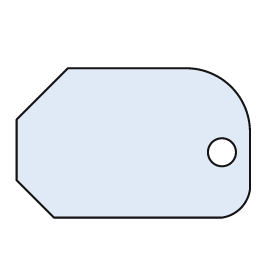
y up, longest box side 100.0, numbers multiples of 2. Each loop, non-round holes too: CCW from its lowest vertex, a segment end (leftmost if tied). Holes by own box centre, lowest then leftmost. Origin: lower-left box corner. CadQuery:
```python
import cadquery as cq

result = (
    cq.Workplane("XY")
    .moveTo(16.0, 0.0)
    .lineTo(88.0, 0.0)
    .threePointArc((96.0, 4.0), (100.0, 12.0))
    .lineTo(100.0, 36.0)
    .threePointArc((92.0, 56.0), (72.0, 64.0))
    .lineTo(22.0, 64.0)
    .lineTo(0.0, 42.0)
    .lineTo(0.0, 16.0)
    .close()
    .moveTo(88.0, 28.0)
    .circle(6.0)
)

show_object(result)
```